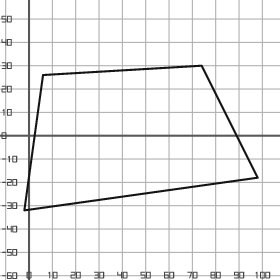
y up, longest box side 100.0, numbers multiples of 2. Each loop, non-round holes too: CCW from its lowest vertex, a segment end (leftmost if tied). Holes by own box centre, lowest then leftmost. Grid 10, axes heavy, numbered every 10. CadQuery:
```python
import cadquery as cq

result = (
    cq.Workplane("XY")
    .moveTo(-2.0, -32.0)
    .lineTo(98.0, -18.0)
    .lineTo(74.0, 30.0)
    .lineTo(6.0, 26.0)
    .close()
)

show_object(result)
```